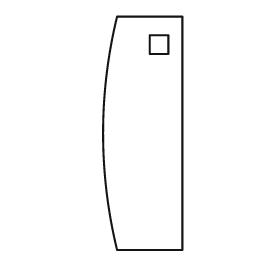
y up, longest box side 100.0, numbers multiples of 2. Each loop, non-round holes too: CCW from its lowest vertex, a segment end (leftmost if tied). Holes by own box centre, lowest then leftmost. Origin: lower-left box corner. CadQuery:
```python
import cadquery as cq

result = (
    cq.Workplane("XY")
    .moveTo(6.0, 0.0)
    .lineTo(34.0, 0.0)
    .lineTo(34.0, 100.0)
    .lineTo(6.0, 100.0)
    .threePointArc((0.0, 50.0), (6.0, 0.0))
    .close()
    .moveTo(20.0, 84.0)
    .lineTo(28.0, 84.0)
    .lineTo(28.0, 92.0)
    .lineTo(20.0, 92.0)
    .close()
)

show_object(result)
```